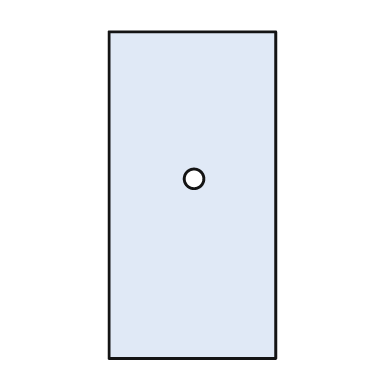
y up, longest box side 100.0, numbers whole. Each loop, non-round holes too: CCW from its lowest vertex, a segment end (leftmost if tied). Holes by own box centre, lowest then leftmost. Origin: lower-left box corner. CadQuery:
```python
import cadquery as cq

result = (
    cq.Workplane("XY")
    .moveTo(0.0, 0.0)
    .lineTo(51.0, 0.0)
    .lineTo(51.0, 100.0)
    .lineTo(0.0, 100.0)
    .close()
    .moveTo(26.0, 55.0)
    .circle(3.0)
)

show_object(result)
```